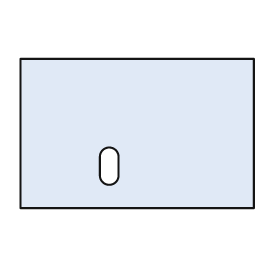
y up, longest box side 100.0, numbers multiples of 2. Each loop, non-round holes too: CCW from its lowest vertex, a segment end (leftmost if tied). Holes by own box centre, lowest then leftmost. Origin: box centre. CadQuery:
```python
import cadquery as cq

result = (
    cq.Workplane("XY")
    .moveTo(-50.0, -32.0)
    .lineTo(50.0, -32.0)
    .lineTo(50.0, 32.0)
    .lineTo(-50.0, 32.0)
    .close()
    .moveTo(-16.0, -18.0)
    .threePointArc((-12.0, -22.0), (-8.0, -18.0))
    .lineTo(-8.0, -10.0)
    .threePointArc((-12.0, -6.0), (-16.0, -10.0))
    .close()
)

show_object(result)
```